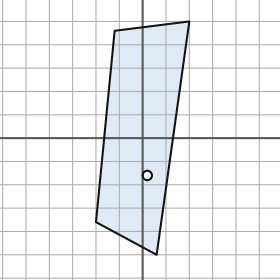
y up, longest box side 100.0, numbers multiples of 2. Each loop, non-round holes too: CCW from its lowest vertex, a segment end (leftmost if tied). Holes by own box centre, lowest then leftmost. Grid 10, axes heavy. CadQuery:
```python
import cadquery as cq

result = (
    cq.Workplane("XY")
    .moveTo(6.0, -50.0)
    .lineTo(20.0, 50.0)
    .lineTo(-12.0, 46.0)
    .lineTo(-20.0, -36.0)
    .close()
    .moveTo(2.0, -16.0)
    .circle(2.0)
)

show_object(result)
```